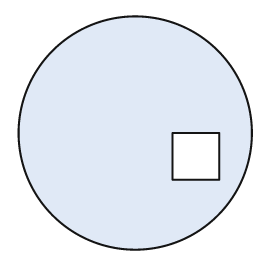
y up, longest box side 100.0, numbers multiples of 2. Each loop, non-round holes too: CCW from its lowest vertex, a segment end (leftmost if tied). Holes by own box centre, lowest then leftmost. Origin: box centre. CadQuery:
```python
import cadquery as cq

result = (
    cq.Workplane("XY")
    .moveTo(0.0, 0.0)
    .circle(50.0)
    .moveTo(16.0, -20.0)
    .lineTo(36.0, -20.0)
    .lineTo(36.0, 0.0)
    .lineTo(16.0, 0.0)
    .close()
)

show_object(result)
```